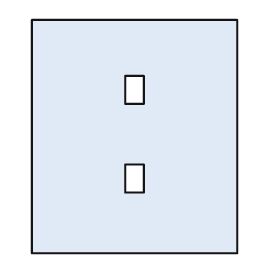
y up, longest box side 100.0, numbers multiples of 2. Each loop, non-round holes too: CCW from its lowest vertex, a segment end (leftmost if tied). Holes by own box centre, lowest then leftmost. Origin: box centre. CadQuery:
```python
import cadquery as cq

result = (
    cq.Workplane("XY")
    .moveTo(-44.0, -50.0)
    .lineTo(44.0, -50.0)
    .lineTo(44.0, 50.0)
    .lineTo(-44.0, 50.0)
    .close()
    .moveTo(-4.0, -24.0)
    .lineTo(4.0, -24.0)
    .lineTo(4.0, -12.0)
    .lineTo(-4.0, -12.0)
    .close()
    .moveTo(-4.0, 14.0)
    .lineTo(4.0, 14.0)
    .lineTo(4.0, 26.0)
    .lineTo(-4.0, 26.0)
    .close()
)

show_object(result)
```